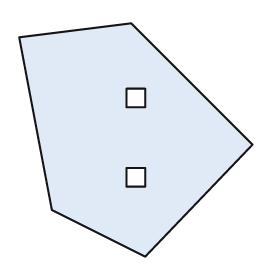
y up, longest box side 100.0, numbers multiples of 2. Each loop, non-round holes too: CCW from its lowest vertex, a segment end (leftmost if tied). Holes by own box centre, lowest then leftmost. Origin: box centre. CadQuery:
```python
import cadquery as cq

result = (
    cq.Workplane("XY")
    .moveTo(4.0, -50.0)
    .lineTo(50.0, -2.0)
    .lineTo(-2.0, 50.0)
    .lineTo(-50.0, 44.0)
    .lineTo(-36.0, -30.0)
    .close()
    .moveTo(-4.0, -20.0)
    .lineTo(4.0, -20.0)
    .lineTo(4.0, -12.0)
    .lineTo(-4.0, -12.0)
    .close()
    .moveTo(-4.0, 14.0)
    .lineTo(4.0, 14.0)
    .lineTo(4.0, 22.0)
    .lineTo(-4.0, 22.0)
    .close()
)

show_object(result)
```